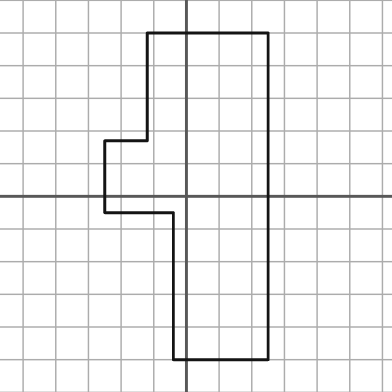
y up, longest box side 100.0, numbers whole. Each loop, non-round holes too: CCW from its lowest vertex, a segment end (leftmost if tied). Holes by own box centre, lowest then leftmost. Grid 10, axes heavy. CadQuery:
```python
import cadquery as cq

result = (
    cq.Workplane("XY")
    .moveTo(-4.0, -50.0)
    .lineTo(25.0, -50.0)
    .lineTo(25.0, 50.0)
    .lineTo(-12.0, 50.0)
    .lineTo(-12.0, 17.0)
    .lineTo(-25.0, 17.0)
    .lineTo(-25.0, -5.0)
    .lineTo(-4.0, -5.0)
    .close()
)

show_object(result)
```